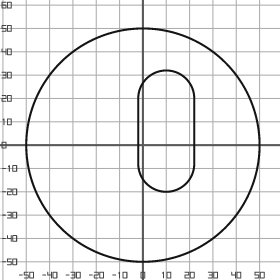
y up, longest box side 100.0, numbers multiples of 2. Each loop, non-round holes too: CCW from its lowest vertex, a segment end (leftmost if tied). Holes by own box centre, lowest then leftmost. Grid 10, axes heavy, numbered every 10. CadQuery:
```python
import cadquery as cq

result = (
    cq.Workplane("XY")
    .moveTo(0.0, 0.0)
    .circle(50.0)
    .moveTo(-2.0, -8.0)
    .threePointArc((10.0, -20.0), (22.0, -8.0))
    .lineTo(22.0, 20.0)
    .threePointArc((10.0, 32.0), (-2.0, 20.0))
    .close()
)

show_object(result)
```